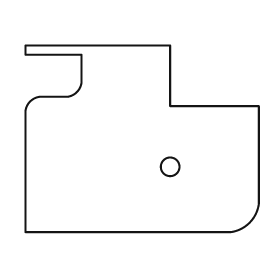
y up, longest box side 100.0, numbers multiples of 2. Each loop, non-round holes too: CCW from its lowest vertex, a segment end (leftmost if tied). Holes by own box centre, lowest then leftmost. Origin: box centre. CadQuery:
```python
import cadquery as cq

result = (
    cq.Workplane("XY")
    .moveTo(-50.0, -40.0)
    .lineTo(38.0, -40.0)
    .threePointArc((46.0, -36.0), (50.0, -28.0))
    .lineTo(50.0, 14.0)
    .lineTo(12.0, 14.0)
    .lineTo(12.0, 40.0)
    .lineTo(-50.0, 40.0)
    .lineTo(-50.0, 36.0)
    .lineTo(-26.0, 36.0)
    .lineTo(-26.0, 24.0)
    .threePointArc((-28.0, 20.0), (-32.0, 18.0))
    .lineTo(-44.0, 18.0)
    .threePointArc((-48.0, 16.0), (-50.0, 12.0))
    .close()
    .moveTo(12.0, -12.0)
    .circle(4.0)
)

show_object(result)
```